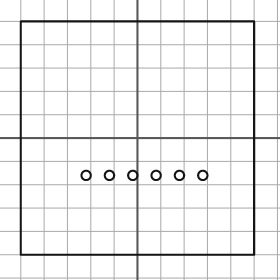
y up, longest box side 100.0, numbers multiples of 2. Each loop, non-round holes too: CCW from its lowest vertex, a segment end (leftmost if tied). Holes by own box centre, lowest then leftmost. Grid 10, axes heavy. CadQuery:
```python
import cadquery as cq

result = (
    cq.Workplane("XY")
    .moveTo(-50.0, -50.0)
    .lineTo(50.0, -50.0)
    .lineTo(50.0, 50.0)
    .lineTo(-50.0, 50.0)
    .close()
    .moveTo(-22.0, -16.0)
    .circle(2.0)
    .moveTo(-12.0, -16.0)
    .circle(2.0)
    .moveTo(-2.0, -16.0)
    .circle(2.0)
    .moveTo(8.0, -16.0)
    .circle(2.0)
    .moveTo(18.0, -16.0)
    .circle(2.0)
    .moveTo(28.0, -16.0)
    .circle(2.0)
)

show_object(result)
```